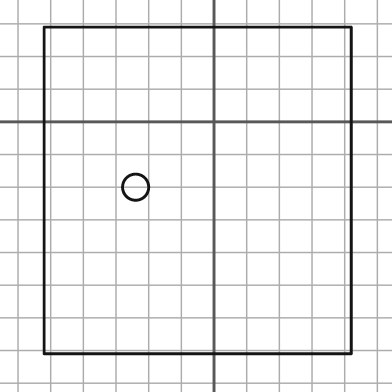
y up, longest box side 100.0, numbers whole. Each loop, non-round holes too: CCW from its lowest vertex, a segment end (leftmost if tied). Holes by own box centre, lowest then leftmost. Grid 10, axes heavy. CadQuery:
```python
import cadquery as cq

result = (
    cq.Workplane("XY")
    .moveTo(-52.0, -71.0)
    .lineTo(42.0, -71.0)
    .lineTo(42.0, 29.0)
    .lineTo(-52.0, 29.0)
    .close()
    .moveTo(-24.0, -20.0)
    .circle(4.0)
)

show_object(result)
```